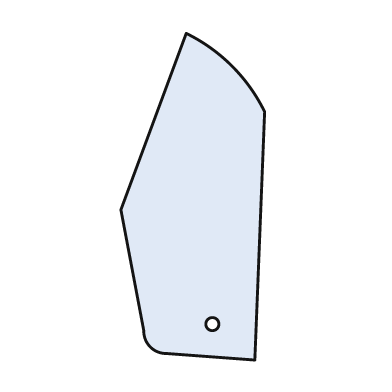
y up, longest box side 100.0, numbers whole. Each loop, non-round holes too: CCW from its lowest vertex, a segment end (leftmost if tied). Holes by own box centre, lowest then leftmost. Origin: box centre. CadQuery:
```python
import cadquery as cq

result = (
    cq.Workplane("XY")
    .moveTo(19.0, -50.0)
    .lineTo(22.0, 26.0)
    .threePointArc((12.0, 40.0), (-2.0, 50.0))
    .lineTo(-22.0, -4.0)
    .lineTo(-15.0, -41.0)
    .threePointArc((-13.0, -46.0), (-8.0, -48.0))
    .close()
    .moveTo(6.0, -39.0)
    .circle(2.0)
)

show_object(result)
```